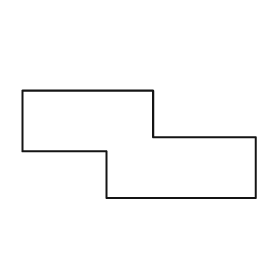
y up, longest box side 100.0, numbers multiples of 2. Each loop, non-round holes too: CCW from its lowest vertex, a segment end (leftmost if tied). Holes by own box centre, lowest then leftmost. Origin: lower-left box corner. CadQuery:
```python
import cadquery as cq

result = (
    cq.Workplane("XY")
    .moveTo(36.0, 0.0)
    .lineTo(100.0, 0.0)
    .lineTo(100.0, 26.0)
    .lineTo(56.0, 26.0)
    .lineTo(56.0, 46.0)
    .lineTo(0.0, 46.0)
    .lineTo(0.0, 20.0)
    .lineTo(36.0, 20.0)
    .close()
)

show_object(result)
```